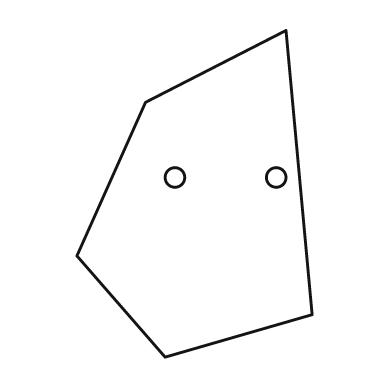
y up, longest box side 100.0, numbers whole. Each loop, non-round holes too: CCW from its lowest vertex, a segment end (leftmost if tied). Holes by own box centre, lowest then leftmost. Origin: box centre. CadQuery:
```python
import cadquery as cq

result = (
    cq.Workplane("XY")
    .moveTo(-9.0, -50.0)
    .lineTo(36.0, -37.0)
    .lineTo(28.0, 50.0)
    .lineTo(-15.0, 28.0)
    .lineTo(-36.0, -19.0)
    .close()
    .moveTo(-6.0, 5.0)
    .circle(3.0)
    .moveTo(25.0, 5.0)
    .circle(3.0)
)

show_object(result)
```